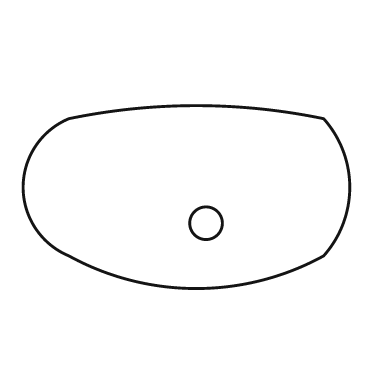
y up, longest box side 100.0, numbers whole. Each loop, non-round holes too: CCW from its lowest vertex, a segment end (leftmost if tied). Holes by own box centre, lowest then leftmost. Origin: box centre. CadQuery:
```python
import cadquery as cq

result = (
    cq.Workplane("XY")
    .moveTo(-36.0, -18.0)
    .threePointArc((3.0, -28.0), (42.0, -18.0))
    .threePointArc((50.0, 3.0), (42.0, 24.0))
    .threePointArc((3.0, 28.0), (-36.0, 24.0))
    .threePointArc((-50.0, 3.0), (-36.0, -18.0))
    .close()
    .moveTo(6.0, -8.0)
    .circle(5.0)
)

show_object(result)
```